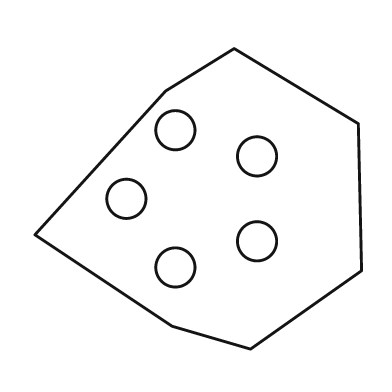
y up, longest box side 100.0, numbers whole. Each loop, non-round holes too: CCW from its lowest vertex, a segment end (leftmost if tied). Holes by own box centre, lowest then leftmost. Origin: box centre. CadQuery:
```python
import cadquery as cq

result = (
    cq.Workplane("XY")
    .moveTo(16.0, -46.0)
    .lineTo(50.0, -22.0)
    .lineTo(49.0, 23.0)
    .lineTo(11.0, 46.0)
    .lineTo(-10.0, 33.0)
    .lineTo(-50.0, -11.0)
    .lineTo(-8.0, -39.0)
    .close()
    .moveTo(-7.0, -21.0)
    .circle(6.0)
    .moveTo(18.0, -13.0)
    .circle(6.0)
    .moveTo(-22.0, 0.0)
    .circle(6.0)
    .moveTo(18.0, 13.0)
    .circle(6.0)
    .moveTo(-7.0, 21.0)
    .circle(6.0)
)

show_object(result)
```